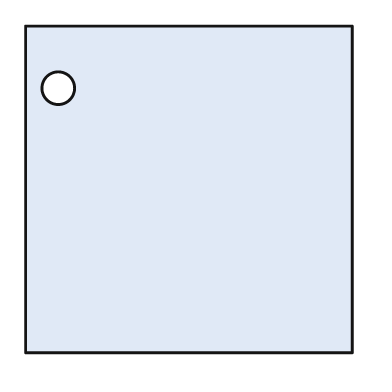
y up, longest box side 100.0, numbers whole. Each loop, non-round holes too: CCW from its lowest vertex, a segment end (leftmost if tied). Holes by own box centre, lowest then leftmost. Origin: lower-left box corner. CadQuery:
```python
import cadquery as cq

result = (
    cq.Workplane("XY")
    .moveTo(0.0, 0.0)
    .lineTo(100.0, 0.0)
    .lineTo(100.0, 100.0)
    .lineTo(0.0, 100.0)
    .close()
    .moveTo(10.0, 81.0)
    .circle(5.0)
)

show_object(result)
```